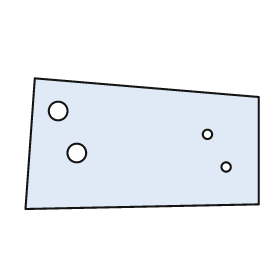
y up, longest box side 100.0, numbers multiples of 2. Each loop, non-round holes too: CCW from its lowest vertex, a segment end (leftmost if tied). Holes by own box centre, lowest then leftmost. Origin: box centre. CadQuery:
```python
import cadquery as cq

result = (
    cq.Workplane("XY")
    .moveTo(-50.0, -28.0)
    .lineTo(50.0, -26.0)
    .lineTo(50.0, 20.0)
    .lineTo(-46.0, 28.0)
    .close()
    .moveTo(36.0, -10.0)
    .circle(2.0)
    .moveTo(-28.0, -4.0)
    .circle(4.0)
    .moveTo(28.0, 4.0)
    .circle(2.0)
    .moveTo(-36.0, 14.0)
    .circle(4.0)
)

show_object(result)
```